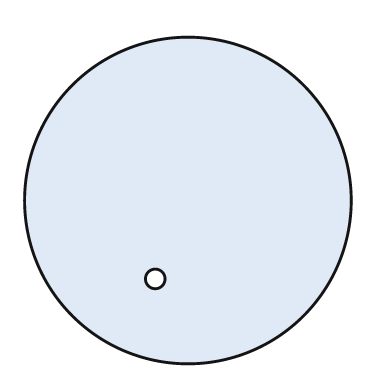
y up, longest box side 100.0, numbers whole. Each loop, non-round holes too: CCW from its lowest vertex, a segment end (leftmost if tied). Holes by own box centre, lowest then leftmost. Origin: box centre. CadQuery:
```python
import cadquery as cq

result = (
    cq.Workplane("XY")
    .moveTo(0.0, 0.0)
    .circle(50.0)
    .moveTo(-10.0, -24.0)
    .circle(3.0)
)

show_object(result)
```